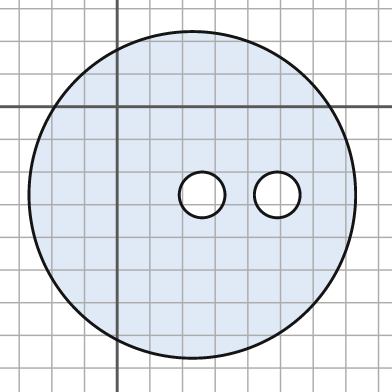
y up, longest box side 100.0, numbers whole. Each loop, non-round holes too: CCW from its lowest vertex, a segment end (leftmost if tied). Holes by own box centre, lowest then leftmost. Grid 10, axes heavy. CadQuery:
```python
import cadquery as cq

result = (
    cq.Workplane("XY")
    .moveTo(23.0, -27.0)
    .circle(50.0)
    .moveTo(26.0, -27.0)
    .circle(7.0)
    .moveTo(49.0, -27.0)
    .circle(7.0)
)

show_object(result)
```